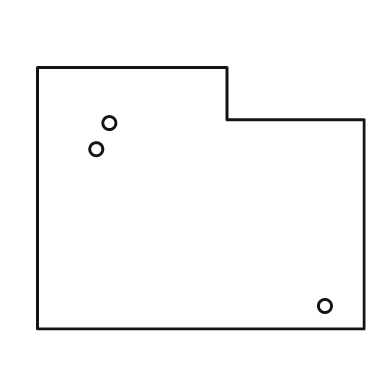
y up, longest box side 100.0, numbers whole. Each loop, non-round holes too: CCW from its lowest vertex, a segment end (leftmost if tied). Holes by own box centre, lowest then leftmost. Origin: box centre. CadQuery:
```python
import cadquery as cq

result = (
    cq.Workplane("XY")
    .moveTo(-50.0, -40.0)
    .lineTo(50.0, -40.0)
    .lineTo(50.0, 24.0)
    .lineTo(8.0, 24.0)
    .lineTo(8.0, 40.0)
    .lineTo(-50.0, 40.0)
    .close()
    .moveTo(38.0, -33.0)
    .circle(2.0)
    .moveTo(-32.0, 15.0)
    .circle(2.0)
    .moveTo(-28.0, 23.0)
    .circle(2.0)
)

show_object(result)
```